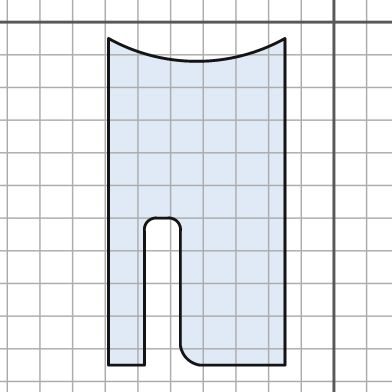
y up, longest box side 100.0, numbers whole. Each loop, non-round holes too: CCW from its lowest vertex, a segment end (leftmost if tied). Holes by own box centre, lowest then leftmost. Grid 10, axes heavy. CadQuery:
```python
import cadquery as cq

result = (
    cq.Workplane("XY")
    .moveTo(-69.0, -105.0)
    .lineTo(-58.0, -105.0)
    .lineTo(-58.0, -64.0)
    .threePointArc((-57.0, -61.0), (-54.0, -60.0))
    .lineTo(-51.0, -60.0)
    .threePointArc((-48.0, -61.0), (-47.0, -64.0))
    .lineTo(-47.0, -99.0)
    .threePointArc((-45.0, -103.0), (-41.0, -105.0))
    .lineTo(-15.0, -105.0)
    .lineTo(-15.0, -5.0)
    .threePointArc((-42.0, -12.0), (-69.0, -5.0))
    .close()
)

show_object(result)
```